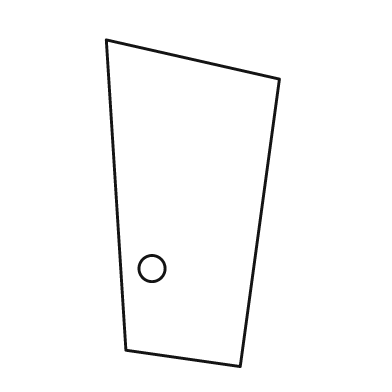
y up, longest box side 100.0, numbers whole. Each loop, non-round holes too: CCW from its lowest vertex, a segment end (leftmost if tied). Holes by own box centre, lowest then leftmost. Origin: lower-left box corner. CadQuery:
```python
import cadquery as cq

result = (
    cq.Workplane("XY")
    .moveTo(41.0, 0.0)
    .lineTo(53.0, 88.0)
    .lineTo(0.0, 100.0)
    .lineTo(6.0, 5.0)
    .close()
    .moveTo(14.0, 30.0)
    .circle(4.0)
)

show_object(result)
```